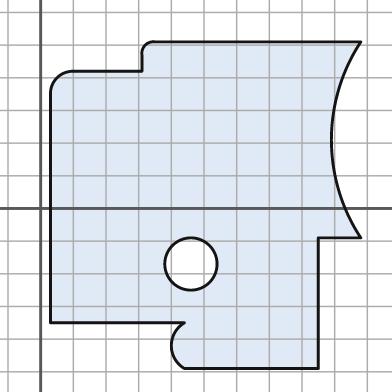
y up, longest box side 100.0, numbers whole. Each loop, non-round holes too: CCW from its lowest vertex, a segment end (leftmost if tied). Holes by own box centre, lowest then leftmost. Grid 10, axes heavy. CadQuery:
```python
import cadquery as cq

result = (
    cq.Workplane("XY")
    .moveTo(44.0, -49.0)
    .lineTo(85.0, -49.0)
    .lineTo(85.0, -9.0)
    .lineTo(98.0, -9.0)
    .threePointArc((89.0, 21.0), (98.0, 51.0))
    .lineTo(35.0, 51.0)
    .threePointArc((32.0, 50.0), (31.0, 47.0))
    .lineTo(31.0, 42.0)
    .lineTo(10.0, 42.0)
    .threePointArc((5.0, 40.0), (3.0, 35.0))
    .lineTo(3.0, -35.0)
    .lineTo(44.0, -35.0)
    .threePointArc((40.0, -42.0), (44.0, -49.0))
    .close()
    .moveTo(46.0, -17.0)
    .circle(8.0)
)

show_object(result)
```